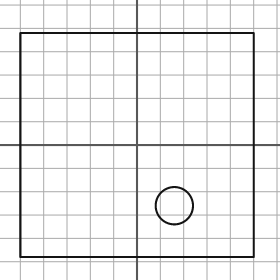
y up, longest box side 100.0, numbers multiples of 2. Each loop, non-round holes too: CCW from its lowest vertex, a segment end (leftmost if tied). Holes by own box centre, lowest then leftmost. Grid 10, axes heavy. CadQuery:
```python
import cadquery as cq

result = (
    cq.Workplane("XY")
    .moveTo(-50.0, -48.0)
    .lineTo(50.0, -48.0)
    .lineTo(50.0, 48.0)
    .lineTo(-50.0, 48.0)
    .close()
    .moveTo(16.0, -26.0)
    .circle(8.0)
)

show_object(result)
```